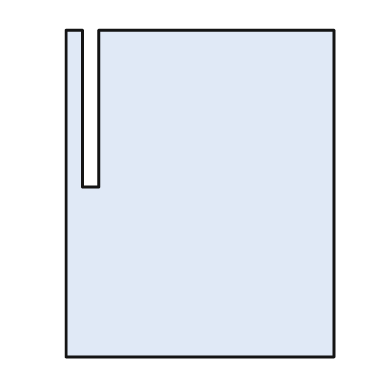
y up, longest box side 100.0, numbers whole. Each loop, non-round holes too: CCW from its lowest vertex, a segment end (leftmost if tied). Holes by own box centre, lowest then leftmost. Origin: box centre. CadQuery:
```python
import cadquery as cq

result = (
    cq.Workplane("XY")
    .moveTo(-41.0, -50.0)
    .lineTo(41.0, -50.0)
    .lineTo(41.0, 50.0)
    .lineTo(-31.0, 50.0)
    .lineTo(-31.0, 2.0)
    .lineTo(-36.0, 2.0)
    .lineTo(-36.0, 50.0)
    .lineTo(-41.0, 50.0)
    .close()
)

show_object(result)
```